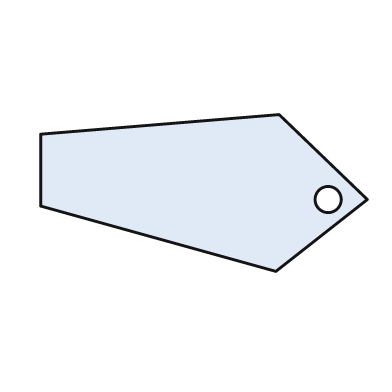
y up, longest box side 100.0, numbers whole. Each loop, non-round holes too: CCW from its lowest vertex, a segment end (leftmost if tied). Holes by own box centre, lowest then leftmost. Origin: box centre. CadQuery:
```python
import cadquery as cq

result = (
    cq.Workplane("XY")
    .moveTo(22.0, -24.0)
    .lineTo(50.0, -2.0)
    .lineTo(23.0, 24.0)
    .lineTo(-50.0, 18.0)
    .lineTo(-50.0, -4.0)
    .close()
    .moveTo(38.0, -2.0)
    .circle(4.0)
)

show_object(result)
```